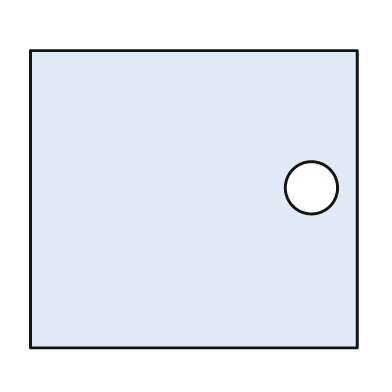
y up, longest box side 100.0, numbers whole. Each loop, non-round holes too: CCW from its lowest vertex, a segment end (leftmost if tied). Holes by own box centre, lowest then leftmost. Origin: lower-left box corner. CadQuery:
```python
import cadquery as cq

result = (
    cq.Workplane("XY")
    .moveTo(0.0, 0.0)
    .lineTo(100.0, 0.0)
    .lineTo(100.0, 91.0)
    .lineTo(0.0, 91.0)
    .close()
    .moveTo(86.0, 49.0)
    .circle(8.0)
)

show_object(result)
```